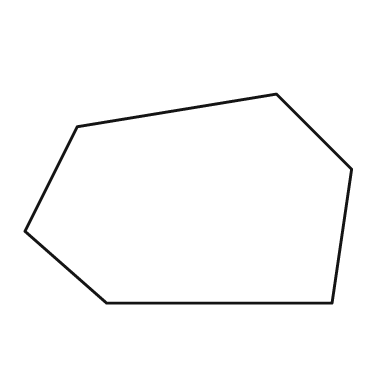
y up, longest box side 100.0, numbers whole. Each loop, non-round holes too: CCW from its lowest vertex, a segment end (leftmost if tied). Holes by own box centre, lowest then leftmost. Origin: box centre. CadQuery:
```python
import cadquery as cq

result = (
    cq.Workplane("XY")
    .moveTo(-25.0, -32.0)
    .lineTo(44.0, -32.0)
    .lineTo(50.0, 9.0)
    .lineTo(27.0, 32.0)
    .lineTo(-34.0, 22.0)
    .lineTo(-50.0, -10.0)
    .close()
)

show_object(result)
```